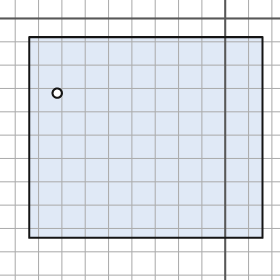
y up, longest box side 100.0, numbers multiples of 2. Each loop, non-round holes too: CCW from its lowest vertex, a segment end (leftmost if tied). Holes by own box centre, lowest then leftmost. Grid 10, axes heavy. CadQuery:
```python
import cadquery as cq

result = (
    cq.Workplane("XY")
    .moveTo(-84.0, -94.0)
    .lineTo(16.0, -94.0)
    .lineTo(16.0, -8.0)
    .lineTo(-84.0, -8.0)
    .close()
    .moveTo(-72.0, -32.0)
    .circle(2.0)
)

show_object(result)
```